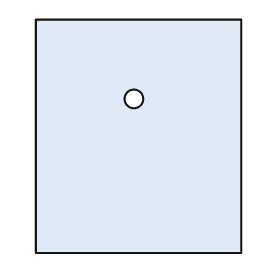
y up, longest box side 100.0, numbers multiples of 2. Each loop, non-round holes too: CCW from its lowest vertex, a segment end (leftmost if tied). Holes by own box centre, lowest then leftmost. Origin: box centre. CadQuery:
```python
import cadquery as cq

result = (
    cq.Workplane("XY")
    .moveTo(-44.0, -50.0)
    .lineTo(44.0, -50.0)
    .lineTo(44.0, 50.0)
    .lineTo(-44.0, 50.0)
    .close()
    .moveTo(-2.0, 16.0)
    .circle(4.0)
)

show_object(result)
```